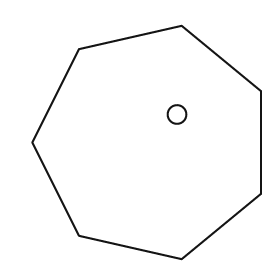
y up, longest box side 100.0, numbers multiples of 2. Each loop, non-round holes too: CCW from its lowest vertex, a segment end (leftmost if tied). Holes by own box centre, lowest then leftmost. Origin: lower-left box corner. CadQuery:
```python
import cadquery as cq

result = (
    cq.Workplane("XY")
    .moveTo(64.0, 0.0)
    .lineTo(98.0, 28.0)
    .lineTo(98.0, 72.0)
    .lineTo(64.0, 100.0)
    .lineTo(20.0, 90.0)
    .lineTo(0.0, 50.0)
    .lineTo(20.0, 10.0)
    .close()
    .moveTo(62.0, 62.0)
    .circle(4.0)
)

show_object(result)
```